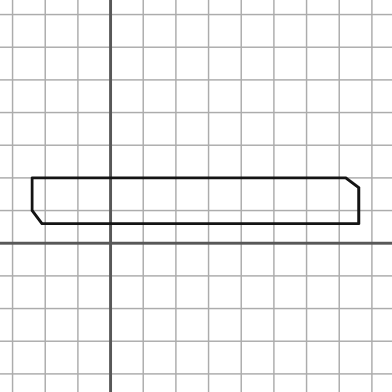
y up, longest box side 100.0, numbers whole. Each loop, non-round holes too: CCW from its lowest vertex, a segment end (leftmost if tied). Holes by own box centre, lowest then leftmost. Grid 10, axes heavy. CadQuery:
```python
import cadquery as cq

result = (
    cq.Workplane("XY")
    .moveTo(-21.0, 6.0)
    .lineTo(76.0, 6.0)
    .lineTo(76.0, 17.0)
    .lineTo(72.0, 20.0)
    .lineTo(-24.0, 20.0)
    .lineTo(-24.0, 10.0)
    .close()
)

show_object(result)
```